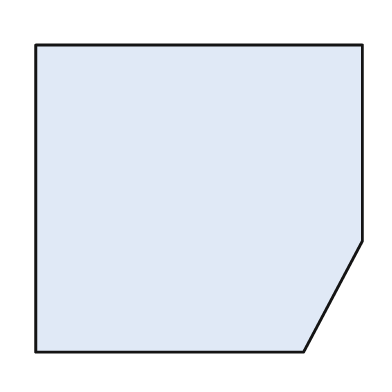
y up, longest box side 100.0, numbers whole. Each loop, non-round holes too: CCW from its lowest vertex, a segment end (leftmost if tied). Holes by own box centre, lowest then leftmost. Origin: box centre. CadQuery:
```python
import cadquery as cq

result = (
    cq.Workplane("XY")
    .moveTo(-50.0, -47.0)
    .lineTo(32.0, -47.0)
    .lineTo(50.0, -13.0)
    .lineTo(50.0, 47.0)
    .lineTo(-50.0, 47.0)
    .close()
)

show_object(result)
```